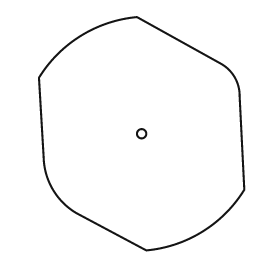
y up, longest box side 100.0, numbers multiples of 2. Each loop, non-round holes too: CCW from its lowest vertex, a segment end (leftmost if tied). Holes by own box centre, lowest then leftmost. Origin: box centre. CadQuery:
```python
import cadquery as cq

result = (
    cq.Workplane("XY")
    .moveTo(2.0, -50.0)
    .threePointArc((26.0, -42.0), (44.0, -24.0))
    .lineTo(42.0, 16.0)
    .threePointArc((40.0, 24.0), (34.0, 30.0))
    .lineTo(-2.0, 50.0)
    .threePointArc((-26.0, 42.0), (-44.0, 24.0))
    .lineTo(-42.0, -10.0)
    .threePointArc((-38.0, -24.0), (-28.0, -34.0))
    .close()
    .moveTo(0.0, 0.0)
    .circle(2.0)
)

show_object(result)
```